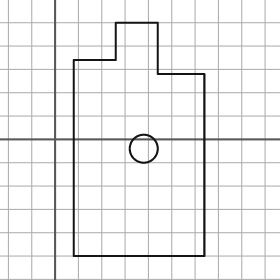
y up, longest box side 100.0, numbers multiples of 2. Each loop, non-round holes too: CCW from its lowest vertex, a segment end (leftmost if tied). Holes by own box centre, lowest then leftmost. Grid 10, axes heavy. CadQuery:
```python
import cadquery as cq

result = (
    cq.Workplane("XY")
    .moveTo(8.0, -50.0)
    .lineTo(64.0, -50.0)
    .lineTo(64.0, 28.0)
    .lineTo(44.0, 28.0)
    .lineTo(44.0, 50.0)
    .lineTo(26.0, 50.0)
    .lineTo(26.0, 34.0)
    .lineTo(8.0, 34.0)
    .close()
    .moveTo(38.0, -4.0)
    .circle(6.0)
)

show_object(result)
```